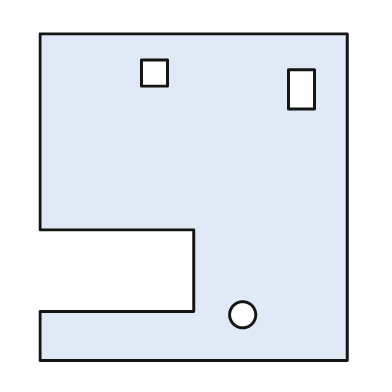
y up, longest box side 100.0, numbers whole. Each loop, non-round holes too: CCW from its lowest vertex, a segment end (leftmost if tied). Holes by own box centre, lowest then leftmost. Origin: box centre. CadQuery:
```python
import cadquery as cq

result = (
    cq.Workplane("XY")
    .moveTo(-47.0, -50.0)
    .lineTo(47.0, -50.0)
    .lineTo(47.0, 50.0)
    .lineTo(-47.0, 50.0)
    .lineTo(-47.0, -10.0)
    .lineTo(0.0, -10.0)
    .lineTo(0.0, -35.0)
    .lineTo(-47.0, -35.0)
    .close()
    .moveTo(15.0, -36.0)
    .circle(4.0)
    .moveTo(29.0, 27.0)
    .lineTo(37.0, 27.0)
    .lineTo(37.0, 39.0)
    .lineTo(29.0, 39.0)
    .close()
    .moveTo(-16.0, 34.0)
    .lineTo(-8.0, 34.0)
    .lineTo(-8.0, 42.0)
    .lineTo(-16.0, 42.0)
    .close()
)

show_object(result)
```